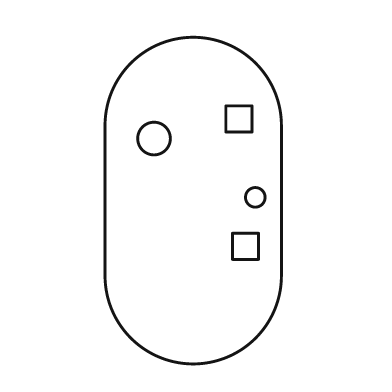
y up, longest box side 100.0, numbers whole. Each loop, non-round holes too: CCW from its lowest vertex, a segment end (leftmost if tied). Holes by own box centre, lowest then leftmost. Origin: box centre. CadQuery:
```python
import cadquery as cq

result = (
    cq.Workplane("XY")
    .moveTo(-27.0, -23.0)
    .threePointArc((0.0, -50.0), (27.0, -23.0))
    .lineTo(27.0, 23.0)
    .threePointArc((0.0, 50.0), (-27.0, 23.0))
    .close()
    .moveTo(12.0, -18.0)
    .lineTo(20.0, -18.0)
    .lineTo(20.0, -10.0)
    .lineTo(12.0, -10.0)
    .close()
    .moveTo(19.0, 1.0)
    .circle(3.0)
    .moveTo(-12.0, 19.0)
    .circle(5.0)
    .moveTo(10.0, 21.0)
    .lineTo(18.0, 21.0)
    .lineTo(18.0, 29.0)
    .lineTo(10.0, 29.0)
    .close()
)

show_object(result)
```